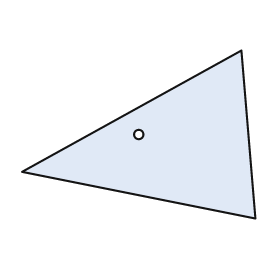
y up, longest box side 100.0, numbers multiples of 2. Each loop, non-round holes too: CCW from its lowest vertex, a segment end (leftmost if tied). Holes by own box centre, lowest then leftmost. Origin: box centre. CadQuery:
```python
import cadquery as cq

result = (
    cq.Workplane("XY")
    .moveTo(50.0, -36.0)
    .lineTo(44.0, 36.0)
    .lineTo(-50.0, -16.0)
    .close()
    .moveTo(0.0, 0.0)
    .circle(2.0)
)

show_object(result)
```